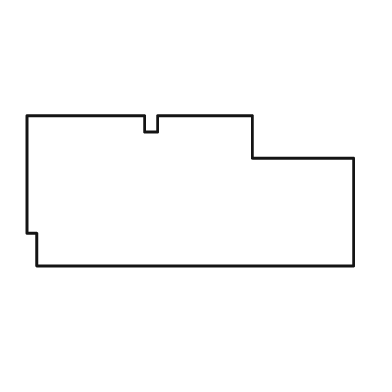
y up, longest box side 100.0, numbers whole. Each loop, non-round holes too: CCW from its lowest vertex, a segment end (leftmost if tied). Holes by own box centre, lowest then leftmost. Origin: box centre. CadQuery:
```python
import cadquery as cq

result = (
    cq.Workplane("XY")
    .moveTo(-47.0, -23.0)
    .lineTo(50.0, -23.0)
    .lineTo(50.0, 10.0)
    .lineTo(19.0, 10.0)
    .lineTo(19.0, 23.0)
    .lineTo(-10.0, 23.0)
    .lineTo(-10.0, 18.0)
    .lineTo(-14.0, 18.0)
    .lineTo(-14.0, 23.0)
    .lineTo(-50.0, 23.0)
    .lineTo(-50.0, -13.0)
    .lineTo(-47.0, -13.0)
    .close()
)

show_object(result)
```